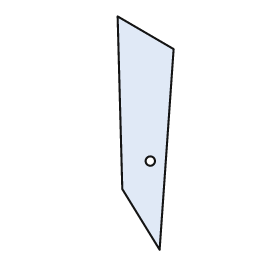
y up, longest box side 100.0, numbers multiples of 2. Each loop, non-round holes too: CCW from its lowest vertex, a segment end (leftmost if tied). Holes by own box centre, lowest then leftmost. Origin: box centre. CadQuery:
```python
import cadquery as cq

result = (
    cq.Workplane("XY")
    .moveTo(6.0, -50.0)
    .lineTo(12.0, 36.0)
    .lineTo(-12.0, 50.0)
    .lineTo(-10.0, -24.0)
    .close()
    .moveTo(2.0, -12.0)
    .circle(2.0)
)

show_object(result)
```